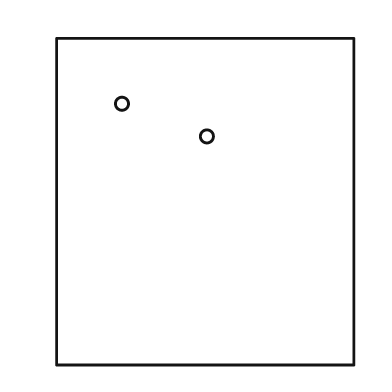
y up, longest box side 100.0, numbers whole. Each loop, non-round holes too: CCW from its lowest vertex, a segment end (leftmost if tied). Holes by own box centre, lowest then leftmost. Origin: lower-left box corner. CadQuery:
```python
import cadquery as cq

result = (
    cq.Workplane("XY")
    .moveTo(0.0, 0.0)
    .lineTo(91.0, 0.0)
    .lineTo(91.0, 100.0)
    .lineTo(0.0, 100.0)
    .close()
    .moveTo(46.0, 70.0)
    .circle(2.0)
    .moveTo(20.0, 80.0)
    .circle(2.0)
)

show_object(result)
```